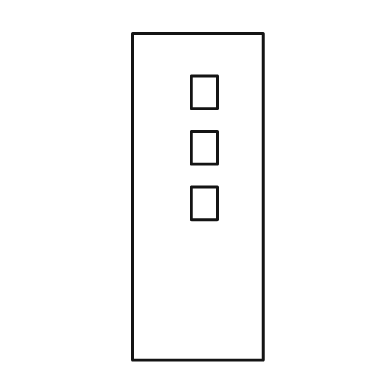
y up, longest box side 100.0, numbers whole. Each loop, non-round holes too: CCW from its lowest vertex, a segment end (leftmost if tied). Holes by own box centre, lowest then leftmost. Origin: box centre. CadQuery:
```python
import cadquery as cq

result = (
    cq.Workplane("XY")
    .moveTo(-20.0, -50.0)
    .lineTo(20.0, -50.0)
    .lineTo(20.0, 50.0)
    .lineTo(-20.0, 50.0)
    .close()
    .moveTo(-2.0, -7.0)
    .lineTo(6.0, -7.0)
    .lineTo(6.0, 3.0)
    .lineTo(-2.0, 3.0)
    .close()
    .moveTo(-2.0, 10.0)
    .lineTo(6.0, 10.0)
    .lineTo(6.0, 20.0)
    .lineTo(-2.0, 20.0)
    .close()
    .moveTo(-2.0, 27.0)
    .lineTo(6.0, 27.0)
    .lineTo(6.0, 37.0)
    .lineTo(-2.0, 37.0)
    .close()
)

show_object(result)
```